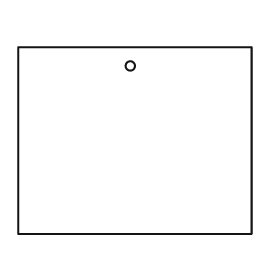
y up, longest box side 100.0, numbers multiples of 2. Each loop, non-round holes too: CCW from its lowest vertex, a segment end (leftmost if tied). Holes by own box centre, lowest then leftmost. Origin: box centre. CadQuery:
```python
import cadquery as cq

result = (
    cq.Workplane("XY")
    .moveTo(-50.0, -40.0)
    .lineTo(50.0, -40.0)
    .lineTo(50.0, 40.0)
    .lineTo(-50.0, 40.0)
    .close()
    .moveTo(-2.0, 32.0)
    .circle(2.0)
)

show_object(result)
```